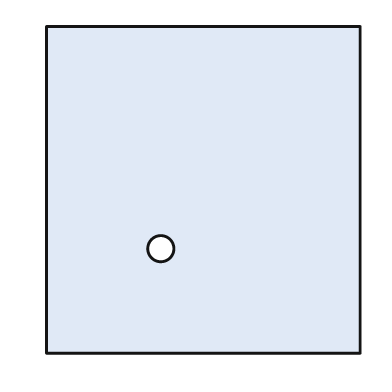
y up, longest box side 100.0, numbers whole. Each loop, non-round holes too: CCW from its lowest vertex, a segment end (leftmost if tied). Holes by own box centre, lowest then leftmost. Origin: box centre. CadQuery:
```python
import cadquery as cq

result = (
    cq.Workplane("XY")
    .moveTo(-48.0, -50.0)
    .lineTo(48.0, -50.0)
    .lineTo(48.0, 50.0)
    .lineTo(-48.0, 50.0)
    .close()
    .moveTo(-13.0, -18.0)
    .circle(4.0)
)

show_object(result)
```